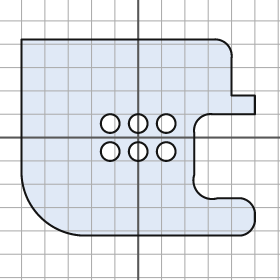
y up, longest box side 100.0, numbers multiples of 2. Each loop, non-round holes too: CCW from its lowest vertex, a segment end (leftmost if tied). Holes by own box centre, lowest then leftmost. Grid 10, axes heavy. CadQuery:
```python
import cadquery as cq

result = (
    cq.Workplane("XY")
    .moveTo(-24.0, -42.0)
    .lineTo(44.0, -42.0)
    .threePointArc((48.0, -40.0), (50.0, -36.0))
    .lineTo(50.0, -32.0)
    .threePointArc((48.0, -28.0), (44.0, -26.0))
    .lineTo(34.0, -26.0)
    .threePointArc((26.0, -24.0), (24.0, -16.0))
    .lineTo(24.0, 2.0)
    .threePointArc((26.0, 8.0), (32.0, 10.0))
    .lineTo(50.0, 10.0)
    .lineTo(50.0, 18.0)
    .lineTo(40.0, 18.0)
    .lineTo(40.0, 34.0)
    .threePointArc((38.0, 40.0), (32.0, 42.0))
    .lineTo(-50.0, 42.0)
    .lineTo(-50.0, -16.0)
    .threePointArc((-42.0, -34.0), (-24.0, -42.0))
    .close()
    .moveTo(-12.0, -6.0)
    .circle(4.0)
    .moveTo(0.0, -6.0)
    .circle(4.0)
    .moveTo(12.0, -6.0)
    .circle(4.0)
    .moveTo(-12.0, 6.0)
    .circle(4.0)
    .moveTo(0.0, 6.0)
    .circle(4.0)
    .moveTo(12.0, 6.0)
    .circle(4.0)
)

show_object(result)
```